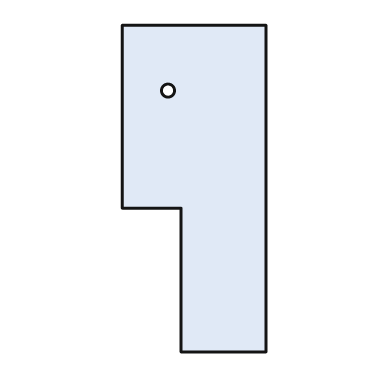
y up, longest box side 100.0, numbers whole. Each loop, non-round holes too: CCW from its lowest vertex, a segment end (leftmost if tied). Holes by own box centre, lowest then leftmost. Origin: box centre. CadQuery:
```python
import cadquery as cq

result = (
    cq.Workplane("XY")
    .moveTo(-4.0, -50.0)
    .lineTo(22.0, -50.0)
    .lineTo(22.0, 50.0)
    .lineTo(-22.0, 50.0)
    .lineTo(-22.0, -6.0)
    .lineTo(-4.0, -6.0)
    .close()
    .moveTo(-8.0, 30.0)
    .circle(2.0)
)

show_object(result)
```